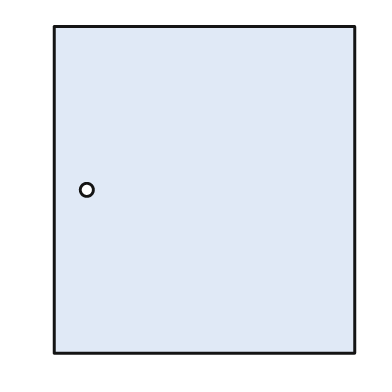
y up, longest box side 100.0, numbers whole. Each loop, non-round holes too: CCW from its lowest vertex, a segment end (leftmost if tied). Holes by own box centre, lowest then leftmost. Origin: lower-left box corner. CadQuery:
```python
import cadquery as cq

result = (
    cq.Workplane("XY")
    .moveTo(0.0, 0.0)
    .lineTo(92.0, 0.0)
    .lineTo(92.0, 100.0)
    .lineTo(0.0, 100.0)
    .close()
    .moveTo(10.0, 50.0)
    .circle(2.0)
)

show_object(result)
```